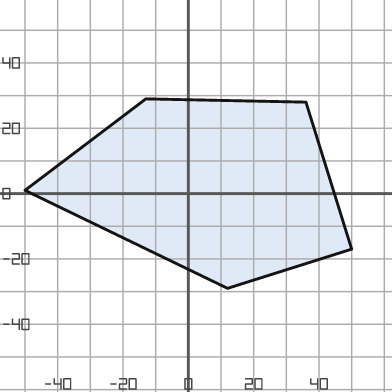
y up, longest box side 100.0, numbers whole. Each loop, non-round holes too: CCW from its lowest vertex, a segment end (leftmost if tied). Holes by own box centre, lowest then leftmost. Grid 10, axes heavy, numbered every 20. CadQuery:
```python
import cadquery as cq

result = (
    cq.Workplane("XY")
    .moveTo(12.0, -29.0)
    .lineTo(50.0, -17.0)
    .lineTo(36.0, 28.0)
    .lineTo(-13.0, 29.0)
    .lineTo(-50.0, 1.0)
    .close()
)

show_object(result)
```